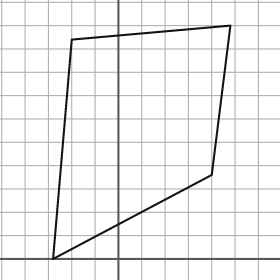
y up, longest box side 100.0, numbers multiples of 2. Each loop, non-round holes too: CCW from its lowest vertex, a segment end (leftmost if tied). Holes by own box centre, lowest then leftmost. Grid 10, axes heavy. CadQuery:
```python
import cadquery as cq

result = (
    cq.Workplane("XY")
    .moveTo(-28.0, 0.0)
    .lineTo(40.0, 36.0)
    .lineTo(48.0, 100.0)
    .lineTo(-20.0, 94.0)
    .close()
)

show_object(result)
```